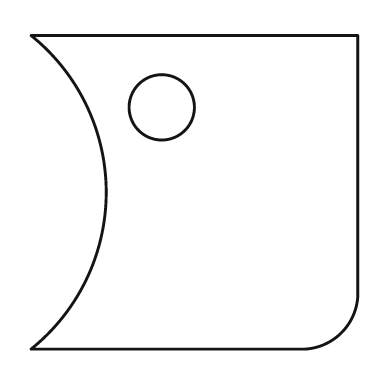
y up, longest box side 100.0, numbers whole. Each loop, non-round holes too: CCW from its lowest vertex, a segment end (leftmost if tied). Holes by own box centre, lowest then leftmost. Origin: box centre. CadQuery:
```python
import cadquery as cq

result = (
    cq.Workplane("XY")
    .moveTo(-50.0, -48.0)
    .lineTo(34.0, -48.0)
    .threePointArc((45.0, -43.0), (50.0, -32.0))
    .lineTo(50.0, 48.0)
    .lineTo(-50.0, 48.0)
    .threePointArc((-27.0, 0.0), (-50.0, -48.0))
    .close()
    .moveTo(-10.0, 26.0)
    .circle(10.0)
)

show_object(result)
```